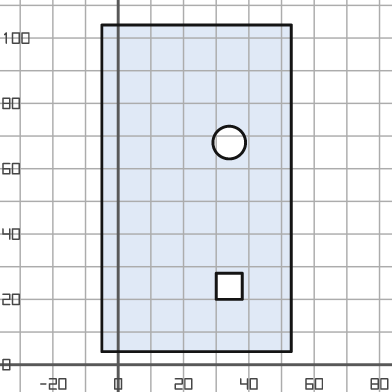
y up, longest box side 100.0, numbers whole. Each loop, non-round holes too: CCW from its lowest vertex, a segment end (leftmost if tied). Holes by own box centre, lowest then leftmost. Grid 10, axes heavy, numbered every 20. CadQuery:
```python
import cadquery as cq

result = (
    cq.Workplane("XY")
    .moveTo(-5.0, 4.0)
    .lineTo(53.0, 4.0)
    .lineTo(53.0, 104.0)
    .lineTo(-5.0, 104.0)
    .close()
    .moveTo(30.0, 20.0)
    .lineTo(38.0, 20.0)
    .lineTo(38.0, 28.0)
    .lineTo(30.0, 28.0)
    .close()
    .moveTo(34.0, 68.0)
    .circle(5.0)
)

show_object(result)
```